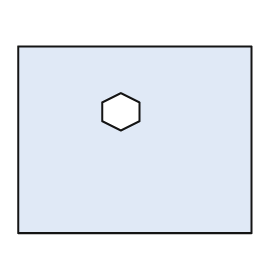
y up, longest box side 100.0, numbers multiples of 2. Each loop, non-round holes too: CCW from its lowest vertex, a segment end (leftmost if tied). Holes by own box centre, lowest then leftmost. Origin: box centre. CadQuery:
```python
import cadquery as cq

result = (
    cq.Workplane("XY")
    .moveTo(-50.0, -40.0)
    .lineTo(50.0, -40.0)
    .lineTo(50.0, 40.0)
    .lineTo(-50.0, 40.0)
    .close()
    .moveTo(-6.0, 4.0)
    .lineTo(2.0, 8.0)
    .lineTo(2.0, 16.0)
    .lineTo(-6.0, 20.0)
    .lineTo(-14.0, 16.0)
    .lineTo(-14.0, 8.0)
    .close()
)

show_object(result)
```